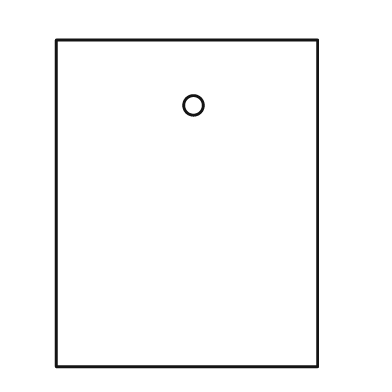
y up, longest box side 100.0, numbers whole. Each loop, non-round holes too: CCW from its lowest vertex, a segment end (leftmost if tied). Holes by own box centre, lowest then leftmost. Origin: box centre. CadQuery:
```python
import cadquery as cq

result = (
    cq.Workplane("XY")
    .moveTo(-40.0, -50.0)
    .lineTo(40.0, -50.0)
    .lineTo(40.0, 50.0)
    .lineTo(-40.0, 50.0)
    .close()
    .moveTo(2.0, 30.0)
    .circle(3.0)
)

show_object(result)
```